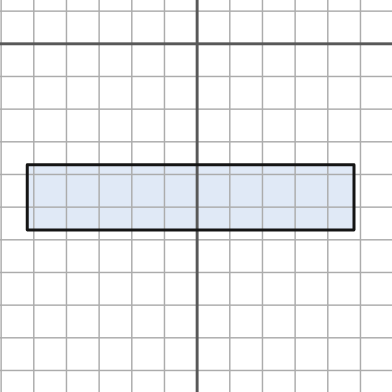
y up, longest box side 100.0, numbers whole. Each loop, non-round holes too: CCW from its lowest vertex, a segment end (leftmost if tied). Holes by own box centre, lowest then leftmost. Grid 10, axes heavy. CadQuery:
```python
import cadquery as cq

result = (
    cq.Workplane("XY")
    .moveTo(-52.0, -57.0)
    .lineTo(48.0, -57.0)
    .lineTo(48.0, -37.0)
    .lineTo(-52.0, -37.0)
    .close()
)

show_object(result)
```